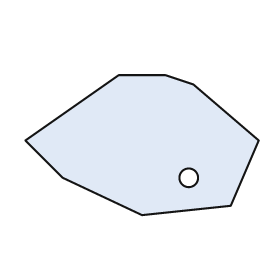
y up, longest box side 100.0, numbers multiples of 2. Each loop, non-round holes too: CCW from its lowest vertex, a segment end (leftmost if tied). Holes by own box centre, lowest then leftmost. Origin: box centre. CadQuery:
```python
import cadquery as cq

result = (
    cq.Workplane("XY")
    .moveTo(0.0, -30.0)
    .lineTo(38.0, -26.0)
    .lineTo(50.0, 2.0)
    .lineTo(22.0, 26.0)
    .lineTo(10.0, 30.0)
    .lineTo(-10.0, 30.0)
    .lineTo(-50.0, 2.0)
    .lineTo(-34.0, -14.0)
    .close()
    .moveTo(20.0, -14.0)
    .circle(4.0)
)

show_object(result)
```